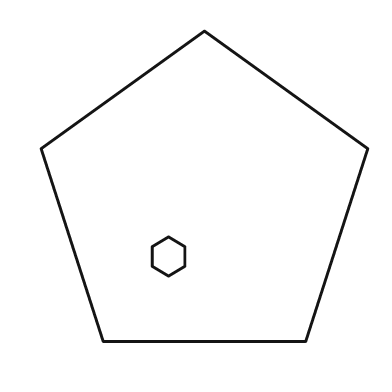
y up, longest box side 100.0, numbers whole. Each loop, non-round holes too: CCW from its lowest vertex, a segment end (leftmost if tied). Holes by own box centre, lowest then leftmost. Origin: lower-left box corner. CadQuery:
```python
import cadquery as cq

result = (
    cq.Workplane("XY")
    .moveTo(19.0, 0.0)
    .lineTo(81.0, 0.0)
    .lineTo(100.0, 59.0)
    .lineTo(50.0, 95.0)
    .lineTo(0.0, 59.0)
    .close()
    .moveTo(39.0, 20.0)
    .lineTo(44.0, 23.0)
    .lineTo(44.0, 29.0)
    .lineTo(39.0, 32.0)
    .lineTo(34.0, 29.0)
    .lineTo(34.0, 23.0)
    .close()
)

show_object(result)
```